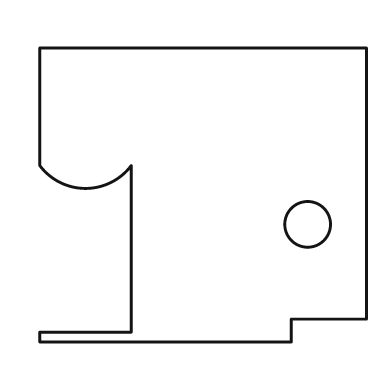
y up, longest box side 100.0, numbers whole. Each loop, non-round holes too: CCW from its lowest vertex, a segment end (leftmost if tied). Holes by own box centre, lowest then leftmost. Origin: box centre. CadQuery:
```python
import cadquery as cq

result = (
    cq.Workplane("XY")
    .moveTo(-50.0, -45.0)
    .lineTo(27.0, -45.0)
    .lineTo(27.0, -38.0)
    .lineTo(50.0, -38.0)
    .lineTo(50.0, 45.0)
    .lineTo(-50.0, 45.0)
    .lineTo(-50.0, 9.0)
    .threePointArc((-36.0, 2.0), (-22.0, 9.0))
    .lineTo(-22.0, -42.0)
    .lineTo(-50.0, -42.0)
    .close()
    .moveTo(32.0, -9.0)
    .circle(7.0)
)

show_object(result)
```